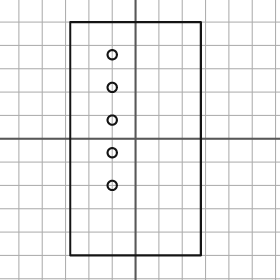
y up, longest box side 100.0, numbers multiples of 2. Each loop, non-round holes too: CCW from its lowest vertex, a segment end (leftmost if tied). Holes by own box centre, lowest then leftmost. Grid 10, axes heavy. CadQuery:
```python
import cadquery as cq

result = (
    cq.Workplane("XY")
    .moveTo(-28.0, -50.0)
    .lineTo(28.0, -50.0)
    .lineTo(28.0, 50.0)
    .lineTo(-28.0, 50.0)
    .close()
    .moveTo(-10.0, -20.0)
    .circle(2.0)
    .moveTo(-10.0, -6.0)
    .circle(2.0)
    .moveTo(-10.0, 8.0)
    .circle(2.0)
    .moveTo(-10.0, 22.0)
    .circle(2.0)
    .moveTo(-10.0, 36.0)
    .circle(2.0)
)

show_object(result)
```